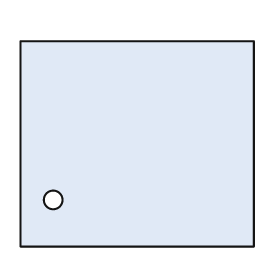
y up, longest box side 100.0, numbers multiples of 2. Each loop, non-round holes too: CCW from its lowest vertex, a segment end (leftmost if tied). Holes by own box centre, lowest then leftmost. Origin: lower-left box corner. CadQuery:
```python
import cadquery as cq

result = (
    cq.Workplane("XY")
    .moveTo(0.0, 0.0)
    .lineTo(100.0, 0.0)
    .lineTo(100.0, 88.0)
    .lineTo(0.0, 88.0)
    .close()
    .moveTo(14.0, 20.0)
    .circle(4.0)
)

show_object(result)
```